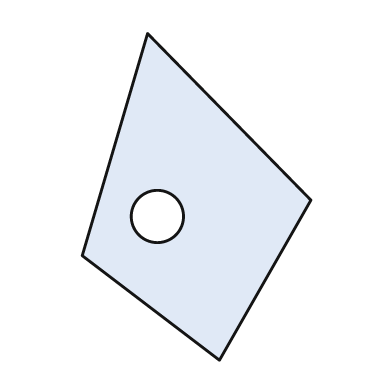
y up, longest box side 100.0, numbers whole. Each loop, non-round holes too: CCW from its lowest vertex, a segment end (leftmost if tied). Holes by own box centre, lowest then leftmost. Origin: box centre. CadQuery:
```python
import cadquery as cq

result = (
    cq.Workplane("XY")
    .moveTo(7.0, -50.0)
    .lineTo(35.0, -1.0)
    .lineTo(-15.0, 50.0)
    .lineTo(-35.0, -18.0)
    .close()
    .moveTo(-12.0, -6.0)
    .circle(8.0)
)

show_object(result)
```